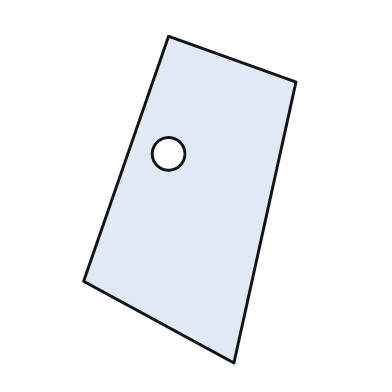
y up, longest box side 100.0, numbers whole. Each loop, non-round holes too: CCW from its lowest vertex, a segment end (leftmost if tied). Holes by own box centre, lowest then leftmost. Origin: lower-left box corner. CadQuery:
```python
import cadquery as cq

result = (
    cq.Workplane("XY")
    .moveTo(46.0, 0.0)
    .lineTo(65.0, 86.0)
    .lineTo(26.0, 100.0)
    .lineTo(0.0, 25.0)
    .close()
    .moveTo(26.0, 64.0)
    .circle(5.0)
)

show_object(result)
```